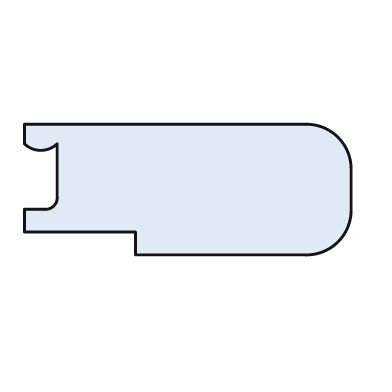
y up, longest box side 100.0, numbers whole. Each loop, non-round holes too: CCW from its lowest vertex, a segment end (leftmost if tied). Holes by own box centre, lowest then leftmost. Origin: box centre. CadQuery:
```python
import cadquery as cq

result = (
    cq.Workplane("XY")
    .moveTo(-16.0, -20.0)
    .lineTo(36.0, -20.0)
    .threePointArc((46.0, -16.0), (50.0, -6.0))
    .lineTo(50.0, 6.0)
    .threePointArc((46.0, 16.0), (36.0, 20.0))
    .lineTo(-50.0, 20.0)
    .lineTo(-50.0, 14.0)
    .threePointArc((-45.0, 12.0), (-40.0, 14.0))
    .lineTo(-40.0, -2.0)
    .threePointArc((-41.0, -5.0), (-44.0, -6.0))
    .lineTo(-50.0, -6.0)
    .lineTo(-50.0, -13.0)
    .lineTo(-16.0, -13.0)
    .close()
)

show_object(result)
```